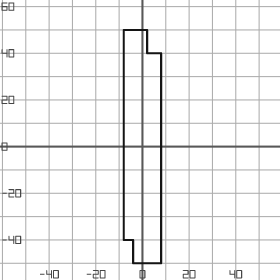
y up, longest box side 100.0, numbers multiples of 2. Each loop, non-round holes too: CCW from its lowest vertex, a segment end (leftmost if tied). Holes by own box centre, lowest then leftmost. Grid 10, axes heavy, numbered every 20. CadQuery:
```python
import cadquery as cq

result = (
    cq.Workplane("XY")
    .moveTo(-4.0, -50.0)
    .lineTo(8.0, -50.0)
    .lineTo(8.0, 40.0)
    .lineTo(2.0, 40.0)
    .lineTo(2.0, 50.0)
    .lineTo(-8.0, 50.0)
    .lineTo(-8.0, -40.0)
    .lineTo(-4.0, -40.0)
    .close()
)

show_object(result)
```